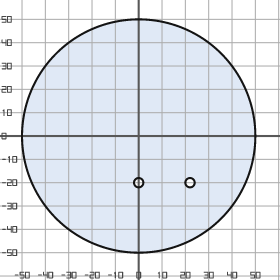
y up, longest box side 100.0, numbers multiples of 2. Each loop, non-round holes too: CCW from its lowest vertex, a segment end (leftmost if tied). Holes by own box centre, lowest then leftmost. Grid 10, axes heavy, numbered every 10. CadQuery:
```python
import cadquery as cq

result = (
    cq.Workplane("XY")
    .moveTo(0.0, 0.0)
    .circle(50.0)
    .moveTo(0.0, -20.0)
    .circle(2.0)
    .moveTo(22.0, -20.0)
    .circle(2.0)
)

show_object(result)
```